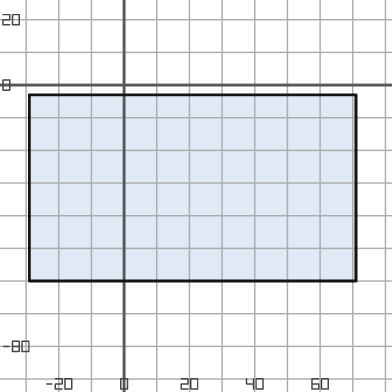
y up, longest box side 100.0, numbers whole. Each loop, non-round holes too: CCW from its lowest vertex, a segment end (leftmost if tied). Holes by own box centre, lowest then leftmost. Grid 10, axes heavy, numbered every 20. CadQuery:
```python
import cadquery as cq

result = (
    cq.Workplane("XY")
    .moveTo(-29.0, -60.0)
    .lineTo(71.0, -60.0)
    .lineTo(71.0, -3.0)
    .lineTo(-29.0, -3.0)
    .close()
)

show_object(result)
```